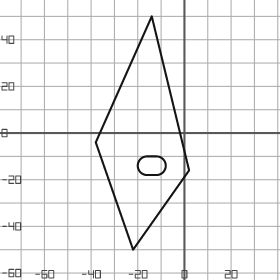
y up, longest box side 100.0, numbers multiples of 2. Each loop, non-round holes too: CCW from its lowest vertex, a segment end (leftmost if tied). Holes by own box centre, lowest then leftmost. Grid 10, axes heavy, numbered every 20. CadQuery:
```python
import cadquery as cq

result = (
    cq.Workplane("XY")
    .moveTo(-22.0, -50.0)
    .lineTo(2.0, -16.0)
    .lineTo(-14.0, 50.0)
    .lineTo(-38.0, -4.0)
    .close()
    .moveTo(-16.0, -18.0)
    .lineTo(-12.0, -18.0)
    .threePointArc((-8.0, -14.0), (-12.0, -10.0))
    .lineTo(-16.0, -10.0)
    .threePointArc((-20.0, -14.0), (-16.0, -18.0))
    .close()
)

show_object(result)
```